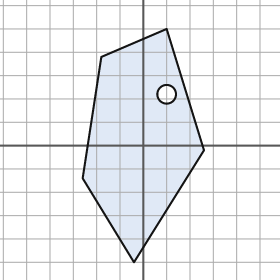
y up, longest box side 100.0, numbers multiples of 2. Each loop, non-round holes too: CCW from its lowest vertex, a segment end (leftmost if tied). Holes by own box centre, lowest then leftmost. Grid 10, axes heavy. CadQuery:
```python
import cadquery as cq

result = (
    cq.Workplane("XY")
    .moveTo(-4.0, -50.0)
    .lineTo(26.0, -2.0)
    .lineTo(10.0, 50.0)
    .lineTo(-18.0, 38.0)
    .lineTo(-26.0, -14.0)
    .close()
    .moveTo(10.0, 22.0)
    .circle(4.0)
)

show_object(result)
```